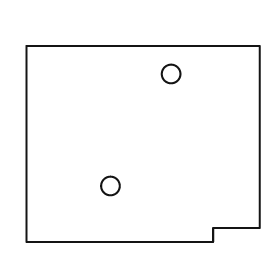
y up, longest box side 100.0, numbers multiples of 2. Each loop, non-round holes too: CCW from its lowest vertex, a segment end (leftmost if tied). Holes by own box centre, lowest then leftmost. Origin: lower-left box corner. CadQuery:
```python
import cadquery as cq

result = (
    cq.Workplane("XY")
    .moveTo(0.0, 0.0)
    .lineTo(80.0, 0.0)
    .lineTo(80.0, 6.0)
    .lineTo(100.0, 6.0)
    .lineTo(100.0, 84.0)
    .lineTo(0.0, 84.0)
    .close()
    .moveTo(36.0, 24.0)
    .circle(4.0)
    .moveTo(62.0, 72.0)
    .circle(4.0)
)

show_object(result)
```